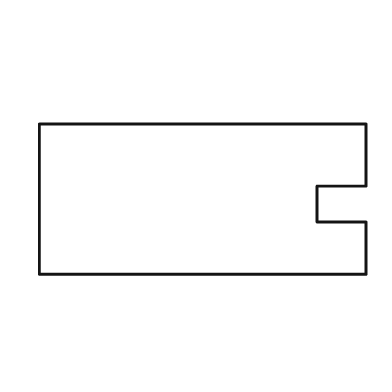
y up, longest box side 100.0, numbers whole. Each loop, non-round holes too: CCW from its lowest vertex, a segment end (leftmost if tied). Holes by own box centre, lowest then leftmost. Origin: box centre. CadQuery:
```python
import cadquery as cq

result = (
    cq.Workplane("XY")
    .moveTo(-50.0, -23.0)
    .lineTo(50.0, -23.0)
    .lineTo(50.0, -7.0)
    .lineTo(35.0, -7.0)
    .lineTo(35.0, 4.0)
    .lineTo(50.0, 4.0)
    .lineTo(50.0, 23.0)
    .lineTo(-50.0, 23.0)
    .close()
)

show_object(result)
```